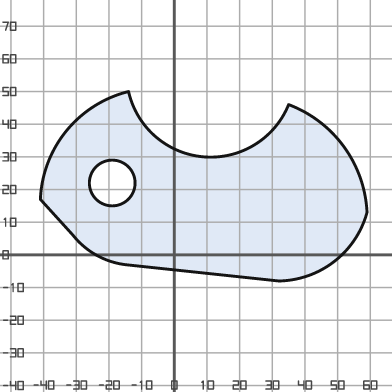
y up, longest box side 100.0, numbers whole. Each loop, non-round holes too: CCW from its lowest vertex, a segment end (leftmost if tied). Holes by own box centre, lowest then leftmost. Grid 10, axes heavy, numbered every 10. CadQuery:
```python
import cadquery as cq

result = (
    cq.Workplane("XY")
    .moveTo(32.0, -8.0)
    .threePointArc((49.0, -2.0), (59.0, 13.0))
    .threePointArc((52.0, 33.0), (35.0, 46.0))
    .threePointArc((9.0, 30.0), (-14.0, 50.0))
    .threePointArc((-33.0, 38.0), (-41.0, 17.0))
    .lineTo(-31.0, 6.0)
    .threePointArc((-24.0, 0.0), (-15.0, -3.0))
    .close()
    .moveTo(-19.0, 22.0)
    .circle(7.0)
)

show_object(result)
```